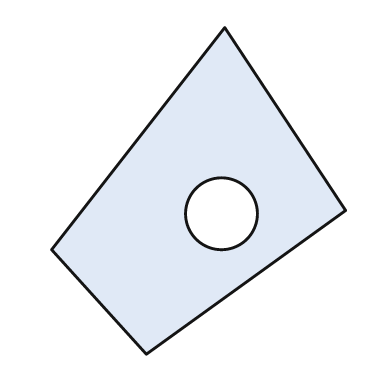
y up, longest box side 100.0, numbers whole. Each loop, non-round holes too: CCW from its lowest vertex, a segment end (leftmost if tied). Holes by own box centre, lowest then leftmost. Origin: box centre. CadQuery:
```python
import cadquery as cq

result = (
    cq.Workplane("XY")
    .moveTo(-16.0, -50.0)
    .lineTo(45.0, -6.0)
    .lineTo(8.0, 50.0)
    .lineTo(-45.0, -18.0)
    .close()
    .moveTo(7.0, -7.0)
    .circle(11.0)
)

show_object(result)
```